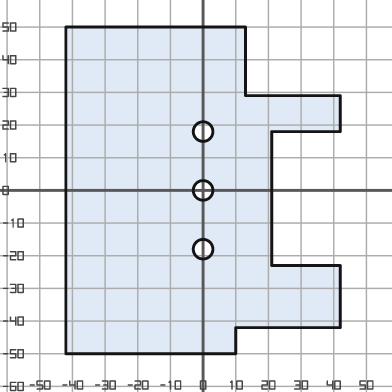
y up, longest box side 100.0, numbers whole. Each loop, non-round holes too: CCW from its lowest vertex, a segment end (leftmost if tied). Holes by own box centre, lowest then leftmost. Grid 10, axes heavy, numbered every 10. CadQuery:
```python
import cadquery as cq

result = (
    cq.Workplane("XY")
    .moveTo(-42.0, -50.0)
    .lineTo(10.0, -50.0)
    .lineTo(10.0, -42.0)
    .lineTo(42.0, -42.0)
    .lineTo(42.0, -23.0)
    .lineTo(21.0, -23.0)
    .lineTo(21.0, 18.0)
    .lineTo(42.0, 18.0)
    .lineTo(42.0, 29.0)
    .lineTo(13.0, 29.0)
    .lineTo(13.0, 50.0)
    .lineTo(-42.0, 50.0)
    .close()
    .moveTo(0.0, -18.0)
    .circle(3.0)
    .moveTo(0.0, 0.0)
    .circle(3.0)
    .moveTo(0.0, 18.0)
    .circle(3.0)
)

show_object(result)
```